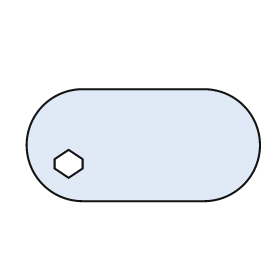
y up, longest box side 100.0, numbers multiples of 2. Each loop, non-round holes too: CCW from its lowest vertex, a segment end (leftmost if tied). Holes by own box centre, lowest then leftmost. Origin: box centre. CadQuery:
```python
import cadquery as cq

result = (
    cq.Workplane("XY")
    .moveTo(-26.0, -24.0)
    .lineTo(26.0, -24.0)
    .threePointArc((50.0, 0.0), (26.0, 24.0))
    .lineTo(-26.0, 24.0)
    .threePointArc((-50.0, 0.0), (-26.0, -24.0))
    .close()
    .moveTo(-32.0, -14.0)
    .lineTo(-26.0, -10.0)
    .lineTo(-26.0, -6.0)
    .lineTo(-32.0, -2.0)
    .lineTo(-38.0, -6.0)
    .lineTo(-38.0, -10.0)
    .close()
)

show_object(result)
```